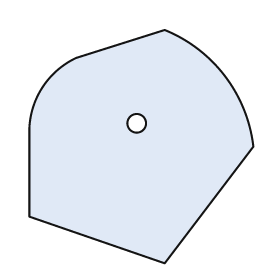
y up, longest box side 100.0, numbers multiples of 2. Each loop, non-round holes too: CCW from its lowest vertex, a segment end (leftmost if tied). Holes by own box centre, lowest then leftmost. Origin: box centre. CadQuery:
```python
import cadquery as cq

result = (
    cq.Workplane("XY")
    .moveTo(10.0, -50.0)
    .lineTo(48.0, 0.0)
    .threePointArc((36.0, 30.0), (10.0, 50.0))
    .lineTo(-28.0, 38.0)
    .threePointArc((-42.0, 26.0), (-48.0, 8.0))
    .lineTo(-48.0, -30.0)
    .close()
    .moveTo(-2.0, 10.0)
    .circle(4.0)
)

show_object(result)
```